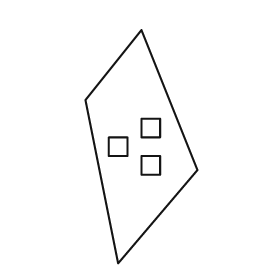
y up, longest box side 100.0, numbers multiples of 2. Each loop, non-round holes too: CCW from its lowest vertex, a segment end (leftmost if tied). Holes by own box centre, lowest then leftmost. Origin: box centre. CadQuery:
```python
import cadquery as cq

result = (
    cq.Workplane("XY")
    .moveTo(-10.0, -50.0)
    .lineTo(24.0, -10.0)
    .lineTo(0.0, 50.0)
    .lineTo(-24.0, 20.0)
    .close()
    .moveTo(0.0, -12.0)
    .lineTo(8.0, -12.0)
    .lineTo(8.0, -4.0)
    .lineTo(0.0, -4.0)
    .close()
    .moveTo(-14.0, -4.0)
    .lineTo(-6.0, -4.0)
    .lineTo(-6.0, 4.0)
    .lineTo(-14.0, 4.0)
    .close()
    .moveTo(0.0, 4.0)
    .lineTo(8.0, 4.0)
    .lineTo(8.0, 12.0)
    .lineTo(0.0, 12.0)
    .close()
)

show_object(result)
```